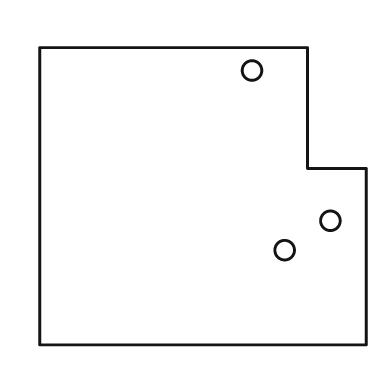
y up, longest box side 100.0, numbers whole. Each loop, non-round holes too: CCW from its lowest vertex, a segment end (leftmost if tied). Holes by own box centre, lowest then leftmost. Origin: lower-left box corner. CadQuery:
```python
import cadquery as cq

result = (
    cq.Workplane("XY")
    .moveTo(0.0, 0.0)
    .lineTo(100.0, 0.0)
    .lineTo(100.0, 54.0)
    .lineTo(82.0, 54.0)
    .lineTo(82.0, 91.0)
    .lineTo(0.0, 91.0)
    .close()
    .moveTo(75.0, 29.0)
    .circle(3.0)
    .moveTo(89.0, 38.0)
    .circle(3.0)
    .moveTo(65.0, 84.0)
    .circle(3.0)
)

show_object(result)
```